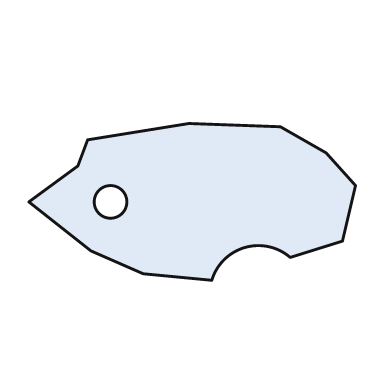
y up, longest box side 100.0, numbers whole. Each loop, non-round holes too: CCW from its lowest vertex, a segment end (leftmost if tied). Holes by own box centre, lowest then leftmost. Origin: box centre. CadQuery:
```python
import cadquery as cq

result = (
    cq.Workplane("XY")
    .moveTo(6.0, -24.0)
    .threePointArc((16.0, -14.0), (30.0, -17.0))
    .lineTo(46.0, -12.0)
    .lineTo(50.0, 5.0)
    .lineTo(41.0, 15.0)
    .lineTo(27.0, 23.0)
    .lineTo(-1.0, 24.0)
    .lineTo(-32.0, 19.0)
    .lineTo(-35.0, 11.0)
    .lineTo(-50.0, 0.0)
    .lineTo(-31.0, -15.0)
    .lineTo(-15.0, -22.0)
    .close()
    .moveTo(-25.0, 0.0)
    .circle(5.0)
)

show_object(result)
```